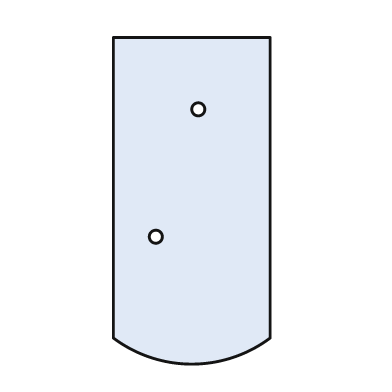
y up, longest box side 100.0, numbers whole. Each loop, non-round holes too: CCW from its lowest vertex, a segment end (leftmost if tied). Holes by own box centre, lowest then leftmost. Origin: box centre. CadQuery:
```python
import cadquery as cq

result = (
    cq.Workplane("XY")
    .moveTo(-24.0, -42.0)
    .threePointArc((0.0, -50.0), (24.0, -42.0))
    .lineTo(24.0, 50.0)
    .lineTo(-24.0, 50.0)
    .close()
    .moveTo(-11.0, -11.0)
    .circle(2.0)
    .moveTo(2.0, 28.0)
    .circle(2.0)
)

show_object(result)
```